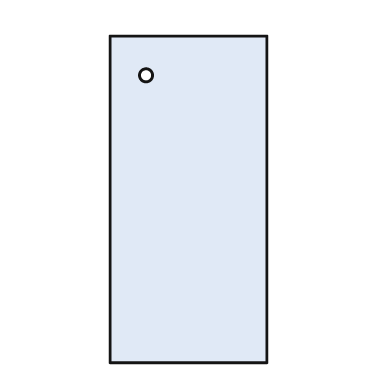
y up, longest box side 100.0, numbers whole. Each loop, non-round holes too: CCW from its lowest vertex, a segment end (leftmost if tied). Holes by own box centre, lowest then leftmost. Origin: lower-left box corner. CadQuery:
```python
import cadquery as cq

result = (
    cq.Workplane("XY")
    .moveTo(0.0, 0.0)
    .lineTo(48.0, 0.0)
    .lineTo(48.0, 100.0)
    .lineTo(0.0, 100.0)
    .close()
    .moveTo(11.0, 88.0)
    .circle(2.0)
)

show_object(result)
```